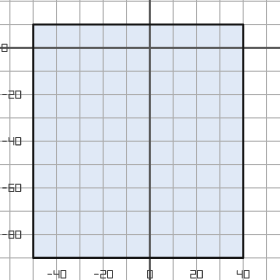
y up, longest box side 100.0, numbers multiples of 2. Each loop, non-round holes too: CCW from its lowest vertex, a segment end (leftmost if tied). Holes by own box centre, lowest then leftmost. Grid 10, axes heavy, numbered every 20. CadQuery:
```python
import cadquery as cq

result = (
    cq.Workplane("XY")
    .moveTo(-50.0, -90.0)
    .lineTo(40.0, -90.0)
    .lineTo(40.0, 10.0)
    .lineTo(-50.0, 10.0)
    .close()
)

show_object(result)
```